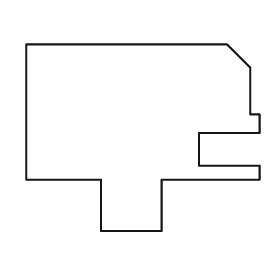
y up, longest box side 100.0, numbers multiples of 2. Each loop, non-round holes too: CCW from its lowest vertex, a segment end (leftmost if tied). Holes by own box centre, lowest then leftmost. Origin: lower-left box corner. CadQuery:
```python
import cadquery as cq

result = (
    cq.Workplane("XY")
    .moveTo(32.0, 0.0)
    .lineTo(58.0, 0.0)
    .lineTo(58.0, 22.0)
    .lineTo(100.0, 22.0)
    .lineTo(100.0, 28.0)
    .lineTo(74.0, 28.0)
    .lineTo(74.0, 42.0)
    .lineTo(100.0, 42.0)
    .lineTo(100.0, 50.0)
    .lineTo(96.0, 50.0)
    .lineTo(96.0, 70.0)
    .lineTo(86.0, 80.0)
    .lineTo(0.0, 80.0)
    .lineTo(0.0, 22.0)
    .lineTo(32.0, 22.0)
    .close()
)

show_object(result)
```